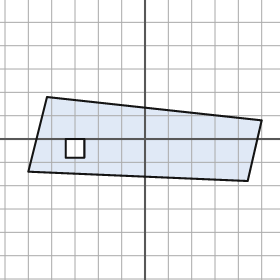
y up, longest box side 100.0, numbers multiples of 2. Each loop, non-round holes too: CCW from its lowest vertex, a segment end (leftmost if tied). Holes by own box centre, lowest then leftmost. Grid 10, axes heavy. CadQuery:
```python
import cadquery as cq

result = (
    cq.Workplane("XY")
    .moveTo(44.0, -18.0)
    .lineTo(50.0, 8.0)
    .lineTo(-42.0, 18.0)
    .lineTo(-50.0, -14.0)
    .close()
    .moveTo(-34.0, -8.0)
    .lineTo(-26.0, -8.0)
    .lineTo(-26.0, 0.0)
    .lineTo(-34.0, 0.0)
    .close()
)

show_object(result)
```